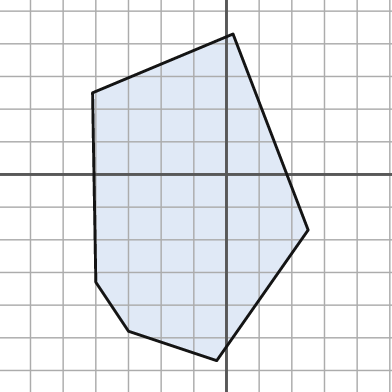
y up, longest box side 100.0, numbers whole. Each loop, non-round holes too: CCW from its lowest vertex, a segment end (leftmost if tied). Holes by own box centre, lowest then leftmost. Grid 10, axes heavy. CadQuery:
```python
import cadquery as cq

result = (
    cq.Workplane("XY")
    .moveTo(-3.0, -57.0)
    .lineTo(25.0, -17.0)
    .lineTo(2.0, 43.0)
    .lineTo(-41.0, 25.0)
    .lineTo(-40.0, -33.0)
    .lineTo(-30.0, -48.0)
    .close()
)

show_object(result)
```